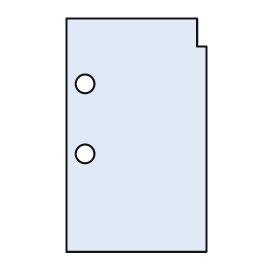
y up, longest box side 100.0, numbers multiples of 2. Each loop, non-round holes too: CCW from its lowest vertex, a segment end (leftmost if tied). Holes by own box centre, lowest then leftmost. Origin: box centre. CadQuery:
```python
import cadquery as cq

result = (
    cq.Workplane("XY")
    .moveTo(-30.0, -50.0)
    .lineTo(30.0, -50.0)
    .lineTo(30.0, 38.0)
    .lineTo(26.0, 38.0)
    .lineTo(26.0, 50.0)
    .lineTo(-30.0, 50.0)
    .close()
    .moveTo(-22.0, -8.0)
    .circle(4.0)
    .moveTo(-22.0, 22.0)
    .circle(4.0)
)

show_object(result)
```